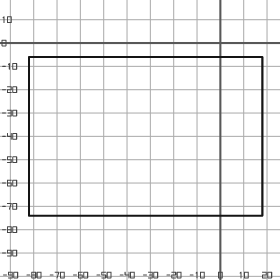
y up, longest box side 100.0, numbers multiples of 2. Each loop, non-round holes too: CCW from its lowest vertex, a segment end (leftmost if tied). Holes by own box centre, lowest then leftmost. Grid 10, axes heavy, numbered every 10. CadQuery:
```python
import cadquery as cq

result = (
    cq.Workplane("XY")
    .moveTo(-82.0, -74.0)
    .lineTo(18.0, -74.0)
    .lineTo(18.0, -6.0)
    .lineTo(-82.0, -6.0)
    .close()
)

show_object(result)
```